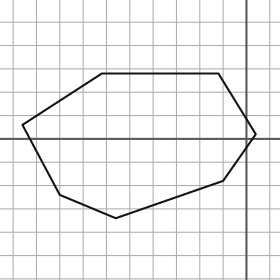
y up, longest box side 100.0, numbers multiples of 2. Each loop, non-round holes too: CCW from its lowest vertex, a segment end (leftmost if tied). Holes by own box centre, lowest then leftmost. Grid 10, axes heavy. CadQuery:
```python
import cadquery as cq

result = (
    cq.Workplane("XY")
    .moveTo(-56.0, -34.0)
    .lineTo(-10.0, -18.0)
    .lineTo(4.0, 2.0)
    .lineTo(-12.0, 28.0)
    .lineTo(-62.0, 28.0)
    .lineTo(-96.0, 6.0)
    .lineTo(-80.0, -24.0)
    .close()
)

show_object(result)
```